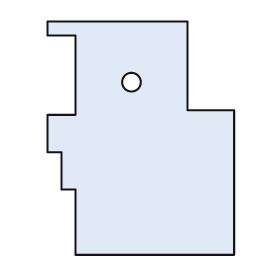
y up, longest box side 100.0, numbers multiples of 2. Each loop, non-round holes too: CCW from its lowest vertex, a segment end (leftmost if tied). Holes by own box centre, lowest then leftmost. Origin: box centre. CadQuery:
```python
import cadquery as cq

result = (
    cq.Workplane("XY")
    .moveTo(-28.0, -50.0)
    .lineTo(40.0, -50.0)
    .lineTo(40.0, 12.0)
    .lineTo(20.0, 12.0)
    .lineTo(20.0, 50.0)
    .lineTo(-40.0, 50.0)
    .lineTo(-40.0, 44.0)
    .lineTo(-28.0, 44.0)
    .lineTo(-28.0, 10.0)
    .lineTo(-40.0, 10.0)
    .lineTo(-40.0, -6.0)
    .lineTo(-34.0, -6.0)
    .lineTo(-34.0, -22.0)
    .lineTo(-28.0, -22.0)
    .close()
    .moveTo(-4.0, 24.0)
    .circle(4.0)
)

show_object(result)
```